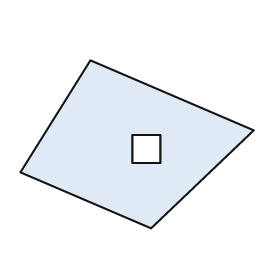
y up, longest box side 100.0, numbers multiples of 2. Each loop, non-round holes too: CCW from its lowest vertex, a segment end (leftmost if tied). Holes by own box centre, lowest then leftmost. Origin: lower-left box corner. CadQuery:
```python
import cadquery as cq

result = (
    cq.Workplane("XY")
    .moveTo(56.0, 0.0)
    .lineTo(100.0, 42.0)
    .lineTo(30.0, 72.0)
    .lineTo(0.0, 24.0)
    .close()
    .moveTo(48.0, 28.0)
    .lineTo(60.0, 28.0)
    .lineTo(60.0, 40.0)
    .lineTo(48.0, 40.0)
    .close()
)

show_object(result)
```